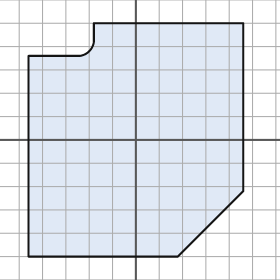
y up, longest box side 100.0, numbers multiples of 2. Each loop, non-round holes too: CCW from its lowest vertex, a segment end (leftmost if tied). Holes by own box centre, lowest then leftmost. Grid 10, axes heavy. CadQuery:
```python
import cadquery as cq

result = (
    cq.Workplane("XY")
    .moveTo(-46.0, -50.0)
    .lineTo(18.0, -50.0)
    .lineTo(46.0, -22.0)
    .lineTo(46.0, 50.0)
    .lineTo(-18.0, 50.0)
    .lineTo(-18.0, 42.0)
    .threePointArc((-20.0, 38.0), (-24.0, 36.0))
    .lineTo(-46.0, 36.0)
    .close()
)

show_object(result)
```